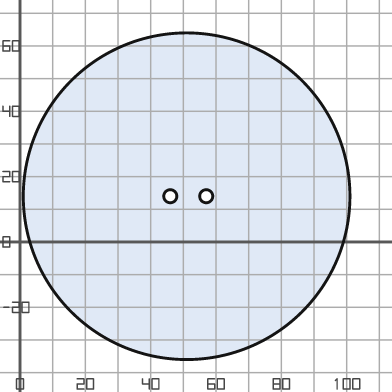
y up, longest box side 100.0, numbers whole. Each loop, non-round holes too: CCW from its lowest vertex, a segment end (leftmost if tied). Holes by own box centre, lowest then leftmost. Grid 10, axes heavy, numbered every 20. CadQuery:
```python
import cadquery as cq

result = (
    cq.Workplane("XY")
    .moveTo(51.0, 14.0)
    .circle(50.0)
    .moveTo(46.0, 14.0)
    .circle(2.0)
    .moveTo(57.0, 14.0)
    .circle(2.0)
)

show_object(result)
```